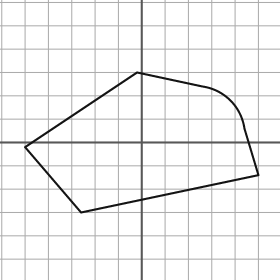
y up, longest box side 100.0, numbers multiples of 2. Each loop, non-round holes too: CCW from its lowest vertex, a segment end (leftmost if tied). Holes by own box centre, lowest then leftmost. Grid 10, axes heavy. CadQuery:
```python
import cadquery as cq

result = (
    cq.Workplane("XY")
    .moveTo(-26.0, -30.0)
    .lineTo(50.0, -14.0)
    .lineTo(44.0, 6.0)
    .threePointArc((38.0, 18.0), (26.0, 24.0))
    .lineTo(-2.0, 30.0)
    .lineTo(-50.0, -2.0)
    .close()
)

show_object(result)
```